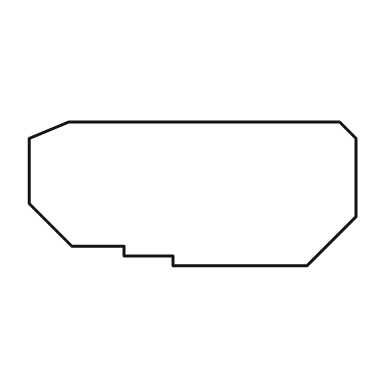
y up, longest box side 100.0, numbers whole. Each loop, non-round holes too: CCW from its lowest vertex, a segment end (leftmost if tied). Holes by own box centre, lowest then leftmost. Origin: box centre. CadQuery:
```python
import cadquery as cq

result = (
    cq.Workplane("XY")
    .moveTo(-6.0, -22.0)
    .lineTo(35.0, -22.0)
    .lineTo(50.0, -7.0)
    .lineTo(50.0, 17.0)
    .lineTo(45.0, 22.0)
    .lineTo(-38.0, 22.0)
    .lineTo(-50.0, 17.0)
    .lineTo(-50.0, -3.0)
    .lineTo(-37.0, -16.0)
    .lineTo(-21.0, -16.0)
    .lineTo(-21.0, -19.0)
    .lineTo(-6.0, -19.0)
    .close()
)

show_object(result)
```